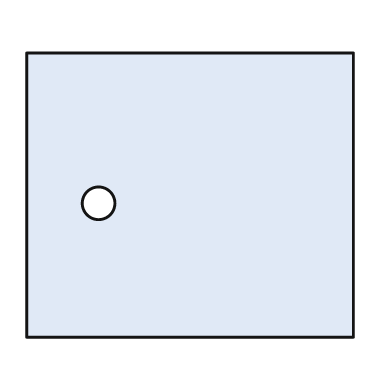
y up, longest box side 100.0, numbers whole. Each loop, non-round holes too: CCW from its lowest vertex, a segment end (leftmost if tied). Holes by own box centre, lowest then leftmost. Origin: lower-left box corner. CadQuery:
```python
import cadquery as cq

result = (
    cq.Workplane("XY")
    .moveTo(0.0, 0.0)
    .lineTo(100.0, 0.0)
    .lineTo(100.0, 87.0)
    .lineTo(0.0, 87.0)
    .close()
    .moveTo(22.0, 41.0)
    .circle(5.0)
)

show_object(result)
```